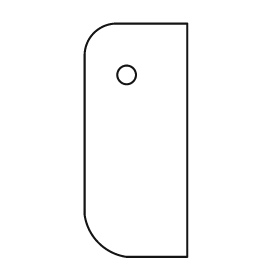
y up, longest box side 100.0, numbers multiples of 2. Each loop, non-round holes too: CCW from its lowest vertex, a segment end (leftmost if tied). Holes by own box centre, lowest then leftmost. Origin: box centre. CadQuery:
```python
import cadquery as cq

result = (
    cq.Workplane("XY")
    .moveTo(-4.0, -50.0)
    .lineTo(22.0, -50.0)
    .lineTo(22.0, 50.0)
    .lineTo(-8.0, 50.0)
    .threePointArc((-18.0, 46.0), (-22.0, 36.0))
    .lineTo(-22.0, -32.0)
    .threePointArc((-16.0, -44.0), (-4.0, -50.0))
    .close()
    .moveTo(-4.0, 28.0)
    .circle(4.0)
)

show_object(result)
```